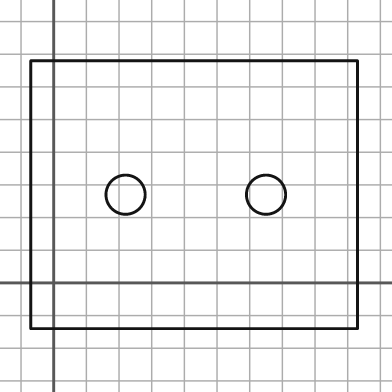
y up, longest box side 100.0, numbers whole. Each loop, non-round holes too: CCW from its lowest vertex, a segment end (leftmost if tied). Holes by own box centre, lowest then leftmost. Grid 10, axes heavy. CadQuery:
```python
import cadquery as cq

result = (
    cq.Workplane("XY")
    .moveTo(-7.0, -14.0)
    .lineTo(93.0, -14.0)
    .lineTo(93.0, 68.0)
    .lineTo(-7.0, 68.0)
    .close()
    .moveTo(22.0, 27.0)
    .circle(6.0)
    .moveTo(65.0, 27.0)
    .circle(6.0)
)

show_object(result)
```